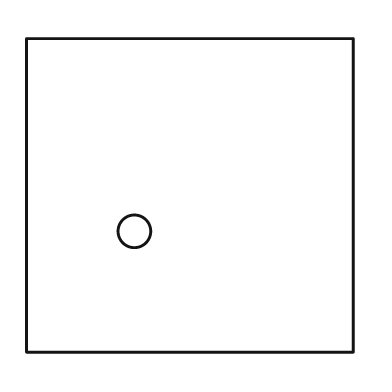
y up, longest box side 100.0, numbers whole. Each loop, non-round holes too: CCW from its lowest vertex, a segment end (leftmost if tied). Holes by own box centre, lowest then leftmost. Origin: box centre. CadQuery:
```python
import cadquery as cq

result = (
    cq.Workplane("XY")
    .moveTo(-50.0, -48.0)
    .lineTo(50.0, -48.0)
    .lineTo(50.0, 48.0)
    .lineTo(-50.0, 48.0)
    .close()
    .moveTo(-17.0, -11.0)
    .circle(5.0)
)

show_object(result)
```